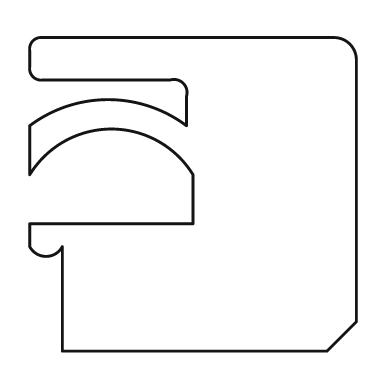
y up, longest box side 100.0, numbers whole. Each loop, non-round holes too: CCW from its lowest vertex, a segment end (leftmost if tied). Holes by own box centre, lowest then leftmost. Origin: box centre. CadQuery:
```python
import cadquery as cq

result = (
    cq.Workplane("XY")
    .moveTo(-40.0, -48.0)
    .lineTo(41.0, -48.0)
    .lineTo(50.0, -39.0)
    .lineTo(50.0, 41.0)
    .threePointArc((48.0, 46.0), (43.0, 48.0))
    .lineTo(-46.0, 48.0)
    .threePointArc((-49.0, 47.0), (-50.0, 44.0))
    .lineTo(-50.0, 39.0)
    .threePointArc((-49.0, 36.0), (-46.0, 35.0))
    .lineTo(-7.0, 35.0)
    .threePointArc((-3.0, 34.0), (-2.0, 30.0))
    .lineTo(-2.0, 21.0)
    .threePointArc((-26.0, 29.0), (-50.0, 21.0))
    .lineTo(-50.0, 6.0)
    .threePointArc((-25.0, 20.0), (0.0, 6.0))
    .lineTo(0.0, -9.0)
    .lineTo(-50.0, -9.0)
    .lineTo(-50.0, -16.0)
    .threePointArc((-45.0, -19.0), (-40.0, -16.0))
    .close()
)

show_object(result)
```